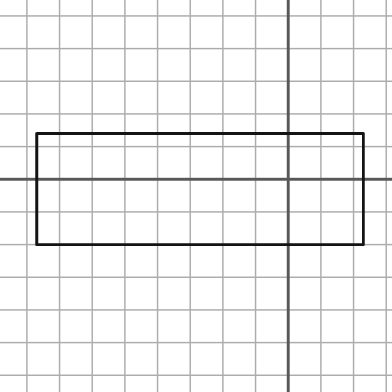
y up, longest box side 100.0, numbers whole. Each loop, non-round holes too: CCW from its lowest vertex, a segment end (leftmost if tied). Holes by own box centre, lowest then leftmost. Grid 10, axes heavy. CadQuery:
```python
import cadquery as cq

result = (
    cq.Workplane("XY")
    .moveTo(-77.0, -20.0)
    .lineTo(23.0, -20.0)
    .lineTo(23.0, 14.0)
    .lineTo(-77.0, 14.0)
    .close()
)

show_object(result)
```